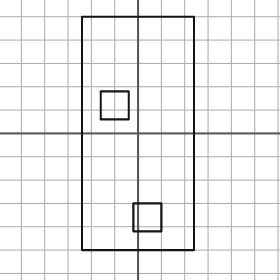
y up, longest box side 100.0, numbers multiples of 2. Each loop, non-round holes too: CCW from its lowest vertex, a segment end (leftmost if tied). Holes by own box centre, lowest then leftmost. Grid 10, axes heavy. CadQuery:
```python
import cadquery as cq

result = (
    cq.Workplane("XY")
    .moveTo(-24.0, -50.0)
    .lineTo(24.0, -50.0)
    .lineTo(24.0, 50.0)
    .lineTo(-24.0, 50.0)
    .close()
    .moveTo(-2.0, -42.0)
    .lineTo(10.0, -42.0)
    .lineTo(10.0, -30.0)
    .lineTo(-2.0, -30.0)
    .close()
    .moveTo(-16.0, 6.0)
    .lineTo(-4.0, 6.0)
    .lineTo(-4.0, 18.0)
    .lineTo(-16.0, 18.0)
    .close()
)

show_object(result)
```